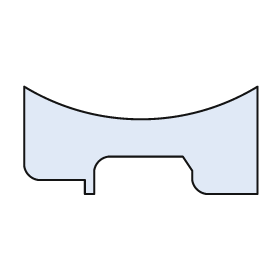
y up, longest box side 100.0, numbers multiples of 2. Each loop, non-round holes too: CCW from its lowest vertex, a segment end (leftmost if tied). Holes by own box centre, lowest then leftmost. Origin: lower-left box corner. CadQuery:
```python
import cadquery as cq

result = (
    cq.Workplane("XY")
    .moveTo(26.0, 0.0)
    .lineTo(30.0, 0.0)
    .lineTo(30.0, 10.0)
    .threePointArc((32.0, 14.0), (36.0, 16.0))
    .lineTo(68.0, 16.0)
    .lineTo(72.0, 10.0)
    .lineTo(72.0, 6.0)
    .threePointArc((74.0, 2.0), (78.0, 0.0))
    .lineTo(100.0, 0.0)
    .lineTo(100.0, 46.0)
    .threePointArc((50.0, 32.0), (0.0, 46.0))
    .lineTo(0.0, 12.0)
    .threePointArc((2.0, 8.0), (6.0, 6.0))
    .lineTo(26.0, 6.0)
    .close()
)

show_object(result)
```